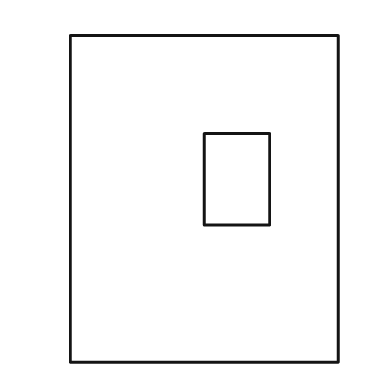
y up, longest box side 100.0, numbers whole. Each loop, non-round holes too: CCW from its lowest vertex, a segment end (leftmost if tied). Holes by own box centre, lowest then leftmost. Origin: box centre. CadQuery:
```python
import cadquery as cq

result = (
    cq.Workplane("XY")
    .moveTo(-41.0, -50.0)
    .lineTo(41.0, -50.0)
    .lineTo(41.0, 50.0)
    .lineTo(-41.0, 50.0)
    .close()
    .moveTo(0.0, -8.0)
    .lineTo(20.0, -8.0)
    .lineTo(20.0, 20.0)
    .lineTo(0.0, 20.0)
    .close()
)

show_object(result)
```